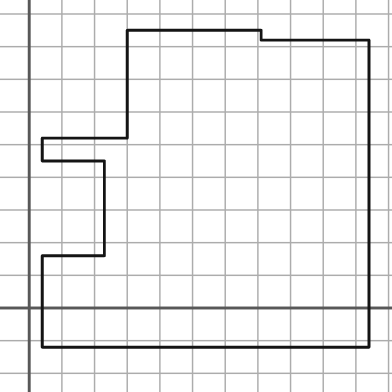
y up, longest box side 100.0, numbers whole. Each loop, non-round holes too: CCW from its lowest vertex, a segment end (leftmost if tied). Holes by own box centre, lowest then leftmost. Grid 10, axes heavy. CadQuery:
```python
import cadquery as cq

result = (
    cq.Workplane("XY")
    .moveTo(4.0, -12.0)
    .lineTo(104.0, -12.0)
    .lineTo(104.0, 82.0)
    .lineTo(71.0, 82.0)
    .lineTo(71.0, 85.0)
    .lineTo(30.0, 85.0)
    .lineTo(30.0, 52.0)
    .lineTo(4.0, 52.0)
    .lineTo(4.0, 45.0)
    .lineTo(23.0, 45.0)
    .lineTo(23.0, 16.0)
    .lineTo(4.0, 16.0)
    .close()
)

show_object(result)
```